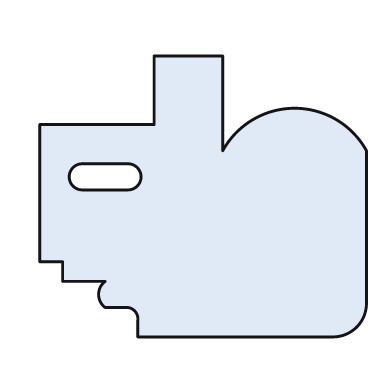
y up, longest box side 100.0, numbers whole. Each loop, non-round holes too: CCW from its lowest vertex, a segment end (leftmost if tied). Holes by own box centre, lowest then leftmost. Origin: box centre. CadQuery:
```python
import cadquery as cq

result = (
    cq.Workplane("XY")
    .moveTo(-20.0, -43.0)
    .lineTo(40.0, -43.0)
    .threePointArc((47.0, -40.0), (50.0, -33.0))
    .lineTo(50.0, 14.0)
    .threePointArc((28.0, 27.0), (6.0, 14.0))
    .lineTo(6.0, 43.0)
    .lineTo(-15.0, 43.0)
    .lineTo(-15.0, 22.0)
    .lineTo(-50.0, 22.0)
    .lineTo(-50.0, -20.0)
    .lineTo(-43.0, -20.0)
    .lineTo(-43.0, -26.0)
    .lineTo(-30.0, -26.0)
    .threePointArc((-32.0, -30.0), (-30.0, -34.0))
    .lineTo(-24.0, -34.0)
    .threePointArc((-21.0, -35.0), (-20.0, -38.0))
    .close()
    .moveTo(-37.0, 2.0)
    .lineTo(-23.0, 2.0)
    .threePointArc((-19.0, 6.0), (-23.0, 10.0))
    .lineTo(-37.0, 10.0)
    .threePointArc((-41.0, 6.0), (-37.0, 2.0))
    .close()
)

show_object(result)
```